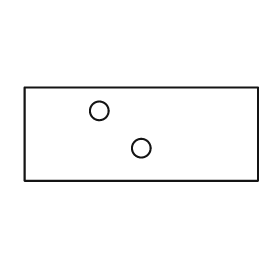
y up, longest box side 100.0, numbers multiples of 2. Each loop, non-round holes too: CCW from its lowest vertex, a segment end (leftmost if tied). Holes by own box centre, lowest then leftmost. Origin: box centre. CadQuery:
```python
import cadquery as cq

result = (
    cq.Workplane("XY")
    .moveTo(-50.0, -20.0)
    .lineTo(50.0, -20.0)
    .lineTo(50.0, 20.0)
    .lineTo(-50.0, 20.0)
    .close()
    .moveTo(0.0, -6.0)
    .circle(4.0)
    .moveTo(-18.0, 10.0)
    .circle(4.0)
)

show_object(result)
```